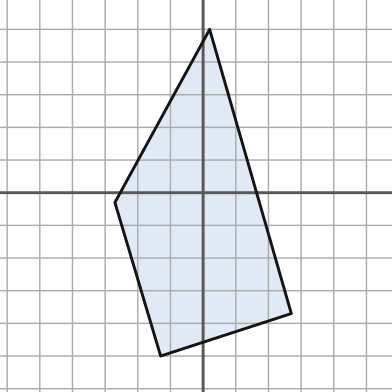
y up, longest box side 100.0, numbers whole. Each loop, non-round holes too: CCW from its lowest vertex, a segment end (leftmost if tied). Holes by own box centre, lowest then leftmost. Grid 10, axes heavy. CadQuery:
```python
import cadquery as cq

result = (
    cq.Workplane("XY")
    .moveTo(-13.0, -50.0)
    .lineTo(27.0, -37.0)
    .lineTo(2.0, 50.0)
    .lineTo(-27.0, -3.0)
    .close()
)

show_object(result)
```